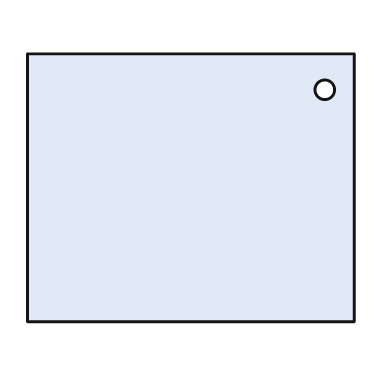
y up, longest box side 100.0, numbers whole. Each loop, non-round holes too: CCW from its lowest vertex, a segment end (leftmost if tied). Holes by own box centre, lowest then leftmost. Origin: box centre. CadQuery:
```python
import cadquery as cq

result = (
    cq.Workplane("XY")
    .moveTo(-50.0, -41.0)
    .lineTo(50.0, -41.0)
    .lineTo(50.0, 41.0)
    .lineTo(-50.0, 41.0)
    .close()
    .moveTo(41.0, 30.0)
    .circle(3.0)
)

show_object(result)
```